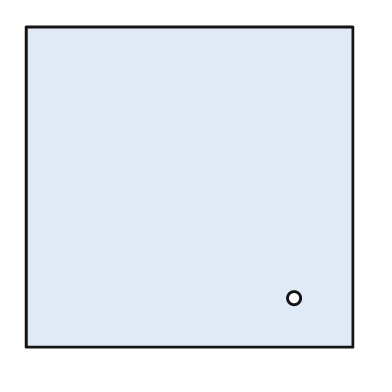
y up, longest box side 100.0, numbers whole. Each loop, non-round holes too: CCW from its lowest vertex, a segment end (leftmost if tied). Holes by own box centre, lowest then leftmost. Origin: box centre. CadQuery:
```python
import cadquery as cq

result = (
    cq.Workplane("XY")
    .moveTo(-50.0, -49.0)
    .lineTo(50.0, -49.0)
    .lineTo(50.0, 49.0)
    .lineTo(-50.0, 49.0)
    .close()
    .moveTo(32.0, -34.0)
    .circle(2.0)
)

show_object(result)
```